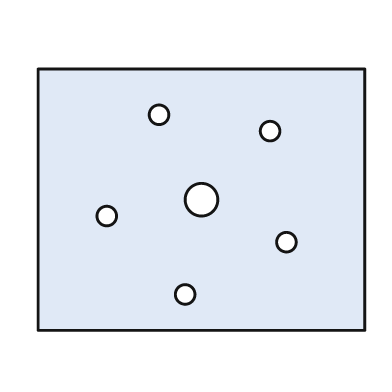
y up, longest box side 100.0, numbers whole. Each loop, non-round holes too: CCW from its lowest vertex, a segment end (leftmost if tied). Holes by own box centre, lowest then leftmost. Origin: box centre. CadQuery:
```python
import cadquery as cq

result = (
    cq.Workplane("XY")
    .moveTo(-50.0, -40.0)
    .lineTo(50.0, -40.0)
    .lineTo(50.0, 40.0)
    .lineTo(-50.0, 40.0)
    .close()
    .moveTo(-5.0, -29.0)
    .circle(3.0)
    .moveTo(26.0, -13.0)
    .circle(3.0)
    .moveTo(-29.0, -5.0)
    .circle(3.0)
    .moveTo(0.0, 0.0)
    .circle(5.0)
    .moveTo(21.0, 21.0)
    .circle(3.0)
    .moveTo(-13.0, 26.0)
    .circle(3.0)
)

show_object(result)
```